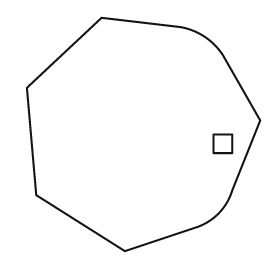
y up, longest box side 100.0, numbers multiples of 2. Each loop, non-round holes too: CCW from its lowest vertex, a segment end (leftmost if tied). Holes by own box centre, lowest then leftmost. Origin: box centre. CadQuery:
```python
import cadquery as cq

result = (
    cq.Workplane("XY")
    .moveTo(-8.0, -50.0)
    .lineTo(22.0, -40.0)
    .threePointArc((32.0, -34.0), (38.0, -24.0))
    .lineTo(50.0, 6.0)
    .lineTo(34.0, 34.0)
    .threePointArc((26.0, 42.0), (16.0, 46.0))
    .lineTo(-18.0, 50.0)
    .lineTo(-50.0, 20.0)
    .lineTo(-46.0, -26.0)
    .close()
    .moveTo(30.0, -8.0)
    .lineTo(38.0, -8.0)
    .lineTo(38.0, 0.0)
    .lineTo(30.0, 0.0)
    .close()
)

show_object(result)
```